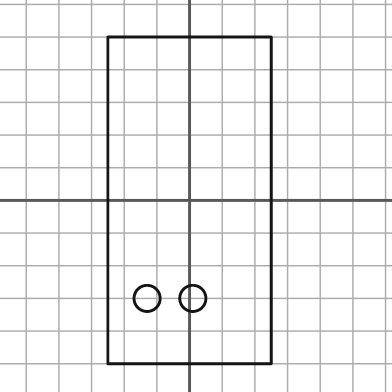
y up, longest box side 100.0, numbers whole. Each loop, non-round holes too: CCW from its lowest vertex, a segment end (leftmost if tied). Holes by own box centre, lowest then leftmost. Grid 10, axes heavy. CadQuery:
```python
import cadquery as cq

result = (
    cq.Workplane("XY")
    .moveTo(-25.0, -50.0)
    .lineTo(25.0, -50.0)
    .lineTo(25.0, 50.0)
    .lineTo(-25.0, 50.0)
    .close()
    .moveTo(-13.0, -30.0)
    .circle(4.0)
    .moveTo(1.0, -30.0)
    .circle(4.0)
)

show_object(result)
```